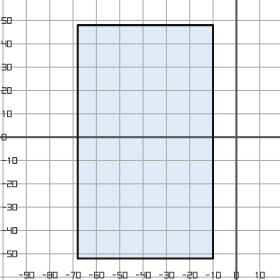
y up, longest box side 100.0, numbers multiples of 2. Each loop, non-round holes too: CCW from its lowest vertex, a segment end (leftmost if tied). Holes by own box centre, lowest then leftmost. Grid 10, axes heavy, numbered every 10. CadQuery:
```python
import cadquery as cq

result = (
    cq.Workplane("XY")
    .moveTo(-68.0, -52.0)
    .lineTo(-10.0, -52.0)
    .lineTo(-10.0, 48.0)
    .lineTo(-68.0, 48.0)
    .close()
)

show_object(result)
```